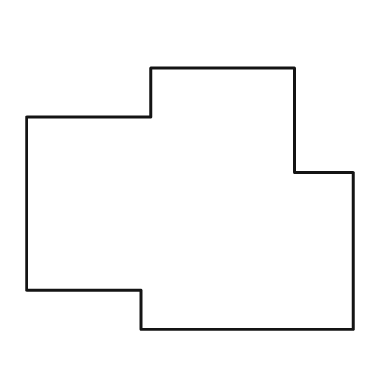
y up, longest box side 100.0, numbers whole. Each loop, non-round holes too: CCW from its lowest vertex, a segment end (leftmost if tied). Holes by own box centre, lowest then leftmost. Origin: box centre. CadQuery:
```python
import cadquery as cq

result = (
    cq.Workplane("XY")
    .moveTo(-15.0, -40.0)
    .lineTo(50.0, -40.0)
    .lineTo(50.0, 8.0)
    .lineTo(32.0, 8.0)
    .lineTo(32.0, 40.0)
    .lineTo(-12.0, 40.0)
    .lineTo(-12.0, 25.0)
    .lineTo(-50.0, 25.0)
    .lineTo(-50.0, -28.0)
    .lineTo(-15.0, -28.0)
    .close()
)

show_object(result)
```